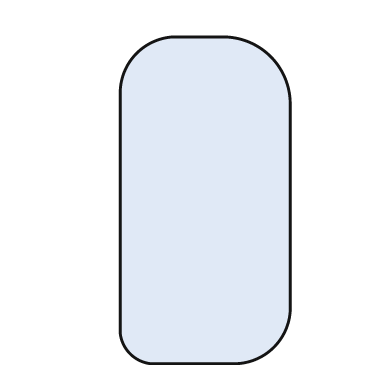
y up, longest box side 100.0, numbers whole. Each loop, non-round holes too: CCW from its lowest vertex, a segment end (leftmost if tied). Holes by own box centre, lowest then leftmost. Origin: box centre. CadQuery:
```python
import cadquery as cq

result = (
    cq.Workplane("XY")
    .moveTo(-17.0, -50.0)
    .lineTo(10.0, -50.0)
    .threePointArc((21.0, -45.0), (26.0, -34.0))
    .lineTo(26.0, 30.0)
    .threePointArc((20.0, 44.0), (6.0, 50.0))
    .lineTo(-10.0, 50.0)
    .threePointArc((-21.0, 45.0), (-26.0, 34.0))
    .lineTo(-26.0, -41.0)
    .threePointArc((-23.0, -47.0), (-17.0, -50.0))
    .close()
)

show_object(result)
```